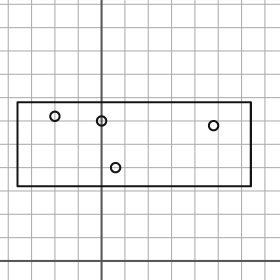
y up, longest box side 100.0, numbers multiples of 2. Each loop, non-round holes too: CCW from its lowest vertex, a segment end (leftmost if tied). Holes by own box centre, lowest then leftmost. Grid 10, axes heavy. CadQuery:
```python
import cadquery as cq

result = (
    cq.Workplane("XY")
    .moveTo(-36.0, 32.0)
    .lineTo(64.0, 32.0)
    .lineTo(64.0, 68.0)
    .lineTo(-36.0, 68.0)
    .close()
    .moveTo(6.0, 40.0)
    .circle(2.0)
    .moveTo(48.0, 58.0)
    .circle(2.0)
    .moveTo(0.0, 60.0)
    .circle(2.0)
    .moveTo(-20.0, 62.0)
    .circle(2.0)
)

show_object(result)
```